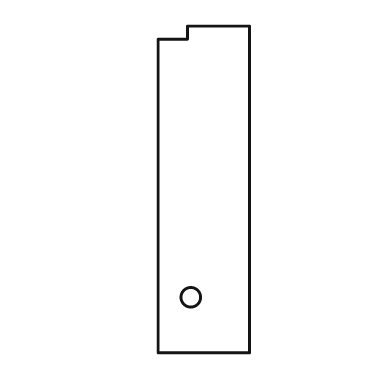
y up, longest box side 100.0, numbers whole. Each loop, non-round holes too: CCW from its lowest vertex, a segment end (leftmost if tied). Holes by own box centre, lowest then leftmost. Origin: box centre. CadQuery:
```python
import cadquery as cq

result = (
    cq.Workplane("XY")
    .moveTo(-14.0, -50.0)
    .lineTo(14.0, -50.0)
    .lineTo(14.0, 50.0)
    .lineTo(-5.0, 50.0)
    .lineTo(-5.0, 46.0)
    .lineTo(-14.0, 46.0)
    .close()
    .moveTo(-4.0, -33.0)
    .circle(3.0)
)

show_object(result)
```